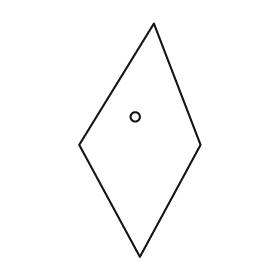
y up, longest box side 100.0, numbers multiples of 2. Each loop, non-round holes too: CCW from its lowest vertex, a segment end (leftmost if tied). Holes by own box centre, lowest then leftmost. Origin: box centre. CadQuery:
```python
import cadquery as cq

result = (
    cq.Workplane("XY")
    .moveTo(0.0, -50.0)
    .lineTo(26.0, -2.0)
    .lineTo(6.0, 50.0)
    .lineTo(-26.0, -2.0)
    .close()
    .moveTo(-2.0, 10.0)
    .circle(2.0)
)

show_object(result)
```